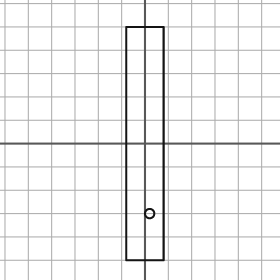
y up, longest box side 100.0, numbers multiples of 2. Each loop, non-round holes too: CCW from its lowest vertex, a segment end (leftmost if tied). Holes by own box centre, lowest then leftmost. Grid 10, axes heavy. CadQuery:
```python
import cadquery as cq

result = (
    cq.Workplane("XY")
    .moveTo(-8.0, -50.0)
    .lineTo(8.0, -50.0)
    .lineTo(8.0, 50.0)
    .lineTo(-8.0, 50.0)
    .close()
    .moveTo(2.0, -30.0)
    .circle(2.0)
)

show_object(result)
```